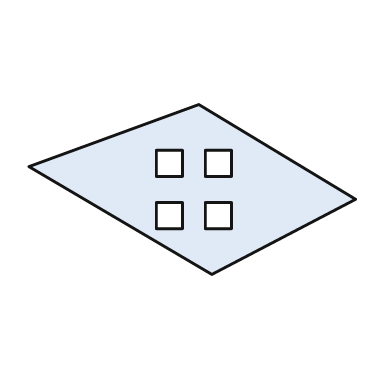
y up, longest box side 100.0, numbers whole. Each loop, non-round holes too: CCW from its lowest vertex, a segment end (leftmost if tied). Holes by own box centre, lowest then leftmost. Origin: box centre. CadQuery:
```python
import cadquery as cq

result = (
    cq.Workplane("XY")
    .moveTo(6.0, -26.0)
    .lineTo(50.0, -3.0)
    .lineTo(2.0, 26.0)
    .lineTo(-50.0, 7.0)
    .close()
    .moveTo(-11.0, -12.0)
    .lineTo(-3.0, -12.0)
    .lineTo(-3.0, -4.0)
    .lineTo(-11.0, -4.0)
    .close()
    .moveTo(4.0, -12.0)
    .lineTo(12.0, -12.0)
    .lineTo(12.0, -4.0)
    .lineTo(4.0, -4.0)
    .close()
    .moveTo(-11.0, 4.0)
    .lineTo(-3.0, 4.0)
    .lineTo(-3.0, 12.0)
    .lineTo(-11.0, 12.0)
    .close()
    .moveTo(4.0, 4.0)
    .lineTo(12.0, 4.0)
    .lineTo(12.0, 12.0)
    .lineTo(4.0, 12.0)
    .close()
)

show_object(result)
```